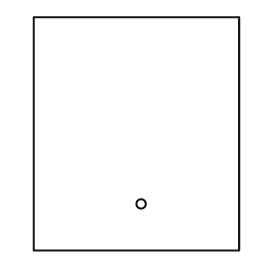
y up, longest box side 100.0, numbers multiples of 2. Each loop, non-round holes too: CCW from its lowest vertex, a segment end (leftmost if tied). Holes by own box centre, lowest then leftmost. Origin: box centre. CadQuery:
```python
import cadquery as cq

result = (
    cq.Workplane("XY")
    .moveTo(-44.0, -50.0)
    .lineTo(44.0, -50.0)
    .lineTo(44.0, 50.0)
    .lineTo(-44.0, 50.0)
    .close()
    .moveTo(2.0, -30.0)
    .circle(2.0)
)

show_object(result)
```